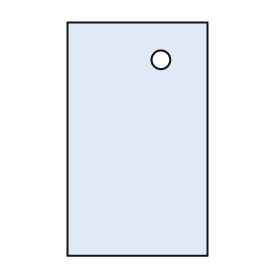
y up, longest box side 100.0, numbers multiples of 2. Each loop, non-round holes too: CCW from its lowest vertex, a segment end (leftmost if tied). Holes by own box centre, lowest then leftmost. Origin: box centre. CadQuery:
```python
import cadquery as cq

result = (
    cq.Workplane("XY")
    .moveTo(-30.0, -50.0)
    .lineTo(30.0, -50.0)
    .lineTo(30.0, 50.0)
    .lineTo(-30.0, 50.0)
    .close()
    .moveTo(10.0, 34.0)
    .circle(4.0)
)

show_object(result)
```